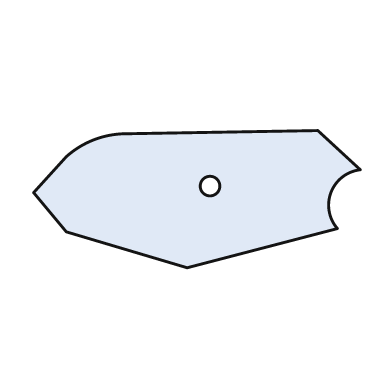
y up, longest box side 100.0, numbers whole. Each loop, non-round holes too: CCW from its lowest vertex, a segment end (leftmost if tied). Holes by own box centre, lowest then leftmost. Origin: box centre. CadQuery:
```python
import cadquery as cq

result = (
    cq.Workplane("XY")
    .moveTo(-3.0, -21.0)
    .lineTo(43.0, -9.0)
    .threePointArc((41.0, 2.0), (50.0, 9.0))
    .lineTo(37.0, 21.0)
    .lineTo(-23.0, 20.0)
    .threePointArc((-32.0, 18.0), (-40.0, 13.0))
    .lineTo(-50.0, 2.0)
    .lineTo(-40.0, -10.0)
    .close()
    .moveTo(4.0, 4.0)
    .circle(3.0)
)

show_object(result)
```